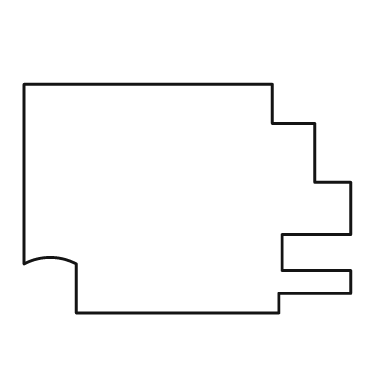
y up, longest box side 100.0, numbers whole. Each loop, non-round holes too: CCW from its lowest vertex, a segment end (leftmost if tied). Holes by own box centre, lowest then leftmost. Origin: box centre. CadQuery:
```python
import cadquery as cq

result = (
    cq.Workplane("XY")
    .moveTo(-34.0, -35.0)
    .lineTo(28.0, -35.0)
    .lineTo(28.0, -29.0)
    .lineTo(50.0, -29.0)
    .lineTo(50.0, -22.0)
    .lineTo(29.0, -22.0)
    .lineTo(29.0, -11.0)
    .lineTo(50.0, -11.0)
    .lineTo(50.0, 5.0)
    .lineTo(39.0, 5.0)
    .lineTo(39.0, 23.0)
    .lineTo(26.0, 23.0)
    .lineTo(26.0, 35.0)
    .lineTo(-50.0, 35.0)
    .lineTo(-50.0, -20.0)
    .threePointArc((-42.0, -18.0), (-34.0, -20.0))
    .close()
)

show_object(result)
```